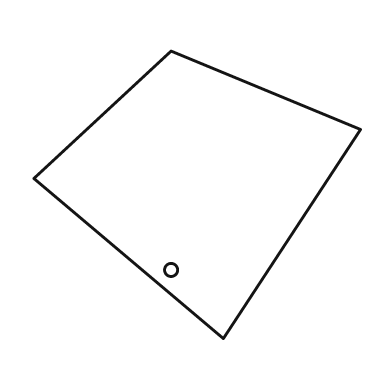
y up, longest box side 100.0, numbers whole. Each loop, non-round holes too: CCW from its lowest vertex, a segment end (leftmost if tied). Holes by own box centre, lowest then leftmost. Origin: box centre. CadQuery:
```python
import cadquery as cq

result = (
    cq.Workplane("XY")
    .moveTo(8.0, -44.0)
    .lineTo(50.0, 20.0)
    .lineTo(-8.0, 44.0)
    .lineTo(-50.0, 5.0)
    .close()
    .moveTo(-8.0, -23.0)
    .circle(2.0)
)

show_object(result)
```